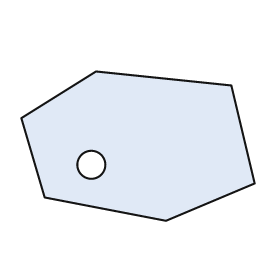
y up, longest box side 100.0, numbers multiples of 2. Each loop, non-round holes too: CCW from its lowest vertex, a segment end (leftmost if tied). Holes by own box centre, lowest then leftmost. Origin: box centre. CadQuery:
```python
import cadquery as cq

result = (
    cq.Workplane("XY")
    .moveTo(12.0, -32.0)
    .lineTo(50.0, -16.0)
    .lineTo(40.0, 26.0)
    .lineTo(-18.0, 32.0)
    .lineTo(-50.0, 12.0)
    .lineTo(-40.0, -22.0)
    .close()
    .moveTo(-20.0, -8.0)
    .circle(6.0)
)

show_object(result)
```